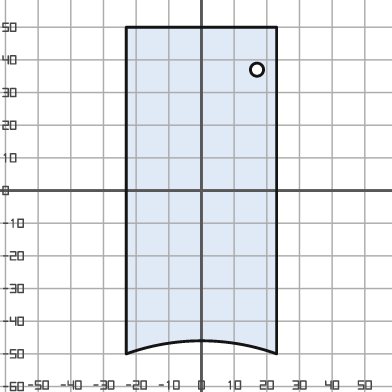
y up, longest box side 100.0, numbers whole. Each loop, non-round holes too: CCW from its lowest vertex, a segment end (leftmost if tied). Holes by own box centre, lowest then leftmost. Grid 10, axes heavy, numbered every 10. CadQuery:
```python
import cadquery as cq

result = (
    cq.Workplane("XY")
    .moveTo(-23.0, -50.0)
    .threePointArc((0.0, -46.0), (23.0, -50.0))
    .lineTo(23.0, 50.0)
    .lineTo(-23.0, 50.0)
    .close()
    .moveTo(17.0, 37.0)
    .circle(2.0)
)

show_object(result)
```